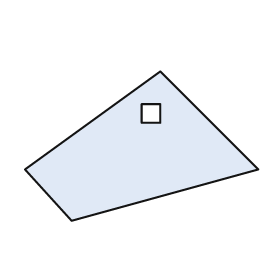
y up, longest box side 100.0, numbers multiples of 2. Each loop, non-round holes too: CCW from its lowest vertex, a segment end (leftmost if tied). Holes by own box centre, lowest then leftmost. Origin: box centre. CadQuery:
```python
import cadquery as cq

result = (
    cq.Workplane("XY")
    .moveTo(-30.0, -32.0)
    .lineTo(50.0, -10.0)
    .lineTo(8.0, 32.0)
    .lineTo(-50.0, -10.0)
    .close()
    .moveTo(0.0, 10.0)
    .lineTo(8.0, 10.0)
    .lineTo(8.0, 18.0)
    .lineTo(0.0, 18.0)
    .close()
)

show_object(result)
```